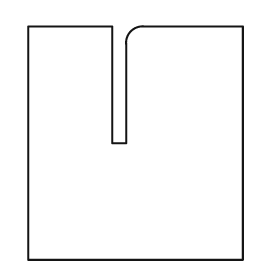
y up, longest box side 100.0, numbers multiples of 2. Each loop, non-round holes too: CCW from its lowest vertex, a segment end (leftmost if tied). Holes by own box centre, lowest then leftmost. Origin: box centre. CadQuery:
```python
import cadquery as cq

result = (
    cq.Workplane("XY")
    .moveTo(-46.0, -50.0)
    .lineTo(46.0, -50.0)
    .lineTo(46.0, 50.0)
    .lineTo(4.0, 50.0)
    .threePointArc((-2.0, 48.0), (-4.0, 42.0))
    .lineTo(-4.0, 0.0)
    .lineTo(-10.0, 0.0)
    .lineTo(-10.0, 50.0)
    .lineTo(-46.0, 50.0)
    .close()
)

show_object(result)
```